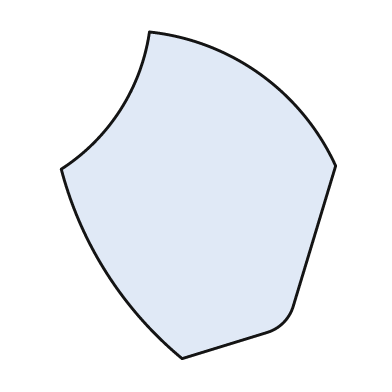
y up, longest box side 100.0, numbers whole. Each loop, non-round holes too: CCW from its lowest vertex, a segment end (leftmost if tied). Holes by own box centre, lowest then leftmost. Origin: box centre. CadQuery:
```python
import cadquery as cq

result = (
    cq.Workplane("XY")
    .moveTo(-5.0, -50.0)
    .lineTo(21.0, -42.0)
    .threePointArc((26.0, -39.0), (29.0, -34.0))
    .lineTo(42.0, 9.0)
    .threePointArc((19.0, 37.0), (-15.0, 50.0))
    .threePointArc((-24.0, 26.0), (-42.0, 8.0))
    .threePointArc((-28.0, -24.0), (-5.0, -50.0))
    .close()
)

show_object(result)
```